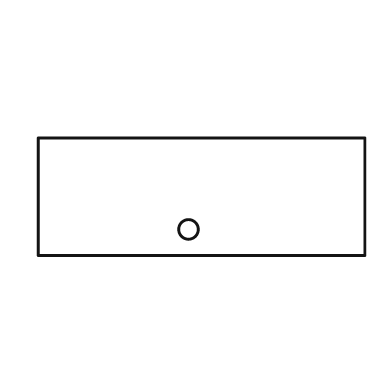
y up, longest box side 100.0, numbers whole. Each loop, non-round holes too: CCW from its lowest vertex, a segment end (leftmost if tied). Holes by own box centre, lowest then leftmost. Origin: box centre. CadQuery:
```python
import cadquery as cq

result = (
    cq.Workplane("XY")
    .moveTo(-50.0, -18.0)
    .lineTo(50.0, -18.0)
    .lineTo(50.0, 18.0)
    .lineTo(-50.0, 18.0)
    .close()
    .moveTo(-4.0, -10.0)
    .circle(3.0)
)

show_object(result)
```